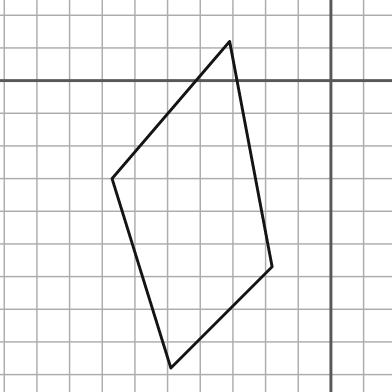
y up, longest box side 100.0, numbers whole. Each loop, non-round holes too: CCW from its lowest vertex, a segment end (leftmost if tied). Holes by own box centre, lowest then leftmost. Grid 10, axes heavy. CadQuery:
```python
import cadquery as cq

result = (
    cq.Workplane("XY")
    .moveTo(-49.0, -88.0)
    .lineTo(-18.0, -57.0)
    .lineTo(-31.0, 12.0)
    .lineTo(-67.0, -30.0)
    .close()
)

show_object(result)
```